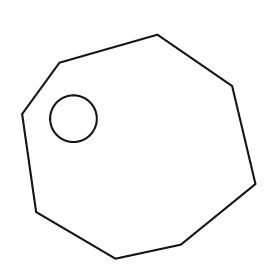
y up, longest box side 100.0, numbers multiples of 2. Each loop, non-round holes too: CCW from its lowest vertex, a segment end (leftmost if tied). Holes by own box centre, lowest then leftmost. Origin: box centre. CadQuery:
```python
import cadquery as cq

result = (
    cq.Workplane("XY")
    .moveTo(-10.0, -48.0)
    .lineTo(18.0, -42.0)
    .lineTo(50.0, -16.0)
    .lineTo(40.0, 26.0)
    .lineTo(8.0, 48.0)
    .lineTo(-34.0, 36.0)
    .lineTo(-50.0, 14.0)
    .lineTo(-44.0, -28.0)
    .close()
    .moveTo(-28.0, 12.0)
    .circle(10.0)
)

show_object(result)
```